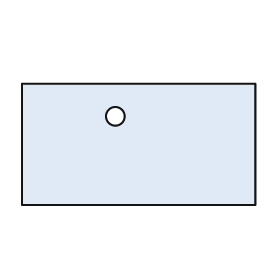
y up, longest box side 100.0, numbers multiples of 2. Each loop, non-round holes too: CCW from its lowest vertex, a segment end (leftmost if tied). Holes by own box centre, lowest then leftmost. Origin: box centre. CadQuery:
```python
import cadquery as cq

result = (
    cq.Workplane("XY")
    .moveTo(-50.0, -26.0)
    .lineTo(50.0, -26.0)
    .lineTo(50.0, 26.0)
    .lineTo(-50.0, 26.0)
    .close()
    .moveTo(-10.0, 12.0)
    .circle(4.0)
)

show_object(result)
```